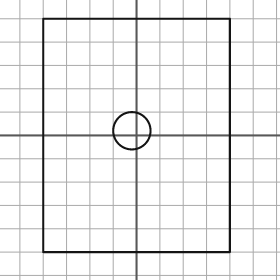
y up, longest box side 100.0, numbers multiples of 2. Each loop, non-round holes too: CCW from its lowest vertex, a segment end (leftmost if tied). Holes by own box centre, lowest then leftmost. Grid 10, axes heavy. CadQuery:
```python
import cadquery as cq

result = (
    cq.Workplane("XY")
    .moveTo(-40.0, -50.0)
    .lineTo(40.0, -50.0)
    .lineTo(40.0, 50.0)
    .lineTo(-40.0, 50.0)
    .close()
    .moveTo(-2.0, 2.0)
    .circle(8.0)
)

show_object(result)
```